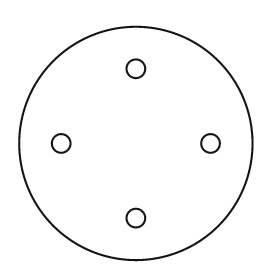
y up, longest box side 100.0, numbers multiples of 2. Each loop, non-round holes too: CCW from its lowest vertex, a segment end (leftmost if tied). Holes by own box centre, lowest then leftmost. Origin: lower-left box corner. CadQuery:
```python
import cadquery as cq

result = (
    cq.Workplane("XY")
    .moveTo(50.0, 50.0)
    .circle(50.0)
    .moveTo(50.0, 18.0)
    .circle(4.0)
    .moveTo(18.0, 50.0)
    .circle(4.0)
    .moveTo(82.0, 50.0)
    .circle(4.0)
    .moveTo(50.0, 82.0)
    .circle(4.0)
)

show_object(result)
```